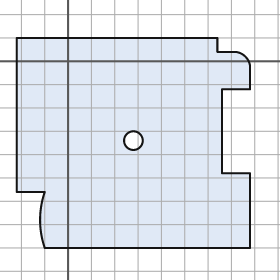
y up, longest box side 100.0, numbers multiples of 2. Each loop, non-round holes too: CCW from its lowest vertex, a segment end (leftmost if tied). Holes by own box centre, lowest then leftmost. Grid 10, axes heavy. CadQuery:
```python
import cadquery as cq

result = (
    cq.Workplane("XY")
    .moveTo(-10.0, -80.0)
    .lineTo(78.0, -80.0)
    .lineTo(78.0, -48.0)
    .lineTo(66.0, -48.0)
    .lineTo(66.0, -12.0)
    .lineTo(78.0, -12.0)
    .lineTo(78.0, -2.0)
    .threePointArc((76.0, 2.0), (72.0, 4.0))
    .lineTo(64.0, 4.0)
    .lineTo(64.0, 10.0)
    .lineTo(-22.0, 10.0)
    .lineTo(-22.0, -56.0)
    .lineTo(-10.0, -56.0)
    .threePointArc((-12.0, -68.0), (-10.0, -80.0))
    .close()
    .moveTo(28.0, -34.0)
    .circle(4.0)
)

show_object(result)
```